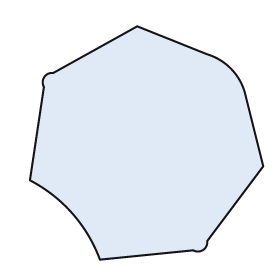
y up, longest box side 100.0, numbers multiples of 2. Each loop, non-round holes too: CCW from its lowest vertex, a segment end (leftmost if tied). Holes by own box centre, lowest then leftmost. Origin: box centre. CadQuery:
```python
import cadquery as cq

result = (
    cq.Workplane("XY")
    .moveTo(-20.0, -50.0)
    .lineTo(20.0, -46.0)
    .threePointArc((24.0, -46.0), (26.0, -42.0))
    .lineTo(50.0, -10.0)
    .lineTo(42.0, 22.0)
    .threePointArc((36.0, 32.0), (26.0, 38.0))
    .lineTo(-4.0, 50.0)
    .lineTo(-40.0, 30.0)
    .threePointArc((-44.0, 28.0), (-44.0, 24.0))
    .lineTo(-50.0, -16.0)
    .threePointArc((-32.0, -30.0), (-20.0, -50.0))
    .close()
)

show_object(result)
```